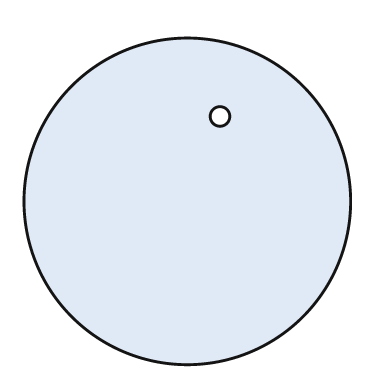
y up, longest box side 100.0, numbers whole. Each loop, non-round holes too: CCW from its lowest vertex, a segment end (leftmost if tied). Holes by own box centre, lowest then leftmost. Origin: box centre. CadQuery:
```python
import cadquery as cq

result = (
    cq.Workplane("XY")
    .moveTo(0.0, 0.0)
    .circle(50.0)
    .moveTo(10.0, 26.0)
    .circle(3.0)
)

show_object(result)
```